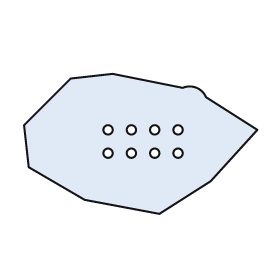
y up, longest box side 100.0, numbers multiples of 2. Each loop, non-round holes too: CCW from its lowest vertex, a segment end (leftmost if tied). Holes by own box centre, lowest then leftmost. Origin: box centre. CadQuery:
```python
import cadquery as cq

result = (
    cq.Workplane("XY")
    .moveTo(8.0, -30.0)
    .lineTo(30.0, -16.0)
    .lineTo(50.0, 6.0)
    .lineTo(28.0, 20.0)
    .threePointArc((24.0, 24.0), (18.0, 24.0))
    .lineTo(-12.0, 30.0)
    .lineTo(-30.0, 28.0)
    .lineTo(-50.0, 8.0)
    .lineTo(-48.0, -10.0)
    .lineTo(-24.0, -24.0)
    .close()
    .moveTo(-14.0, -4.0)
    .circle(2.0)
    .moveTo(-4.0, -4.0)
    .circle(2.0)
    .moveTo(6.0, -4.0)
    .circle(2.0)
    .moveTo(16.0, -4.0)
    .circle(2.0)
    .moveTo(-14.0, 6.0)
    .circle(2.0)
    .moveTo(-4.0, 6.0)
    .circle(2.0)
    .moveTo(6.0, 6.0)
    .circle(2.0)
    .moveTo(16.0, 6.0)
    .circle(2.0)
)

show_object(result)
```